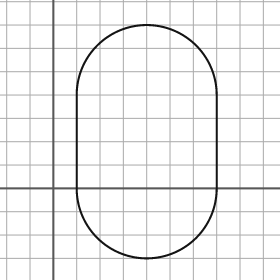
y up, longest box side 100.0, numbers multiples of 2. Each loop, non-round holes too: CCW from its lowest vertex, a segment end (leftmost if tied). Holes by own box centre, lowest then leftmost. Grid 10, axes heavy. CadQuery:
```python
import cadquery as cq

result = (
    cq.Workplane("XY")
    .moveTo(10.0, 0.0)
    .threePointArc((40.0, -30.0), (70.0, 0.0))
    .lineTo(70.0, 40.0)
    .threePointArc((40.0, 70.0), (10.0, 40.0))
    .close()
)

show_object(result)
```